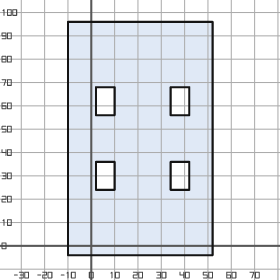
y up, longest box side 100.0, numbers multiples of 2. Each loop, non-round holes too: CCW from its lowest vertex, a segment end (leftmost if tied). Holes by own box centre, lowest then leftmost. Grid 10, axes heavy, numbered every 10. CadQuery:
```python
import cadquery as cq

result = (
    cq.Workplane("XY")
    .moveTo(-10.0, -4.0)
    .lineTo(52.0, -4.0)
    .lineTo(52.0, 96.0)
    .lineTo(-10.0, 96.0)
    .close()
    .moveTo(2.0, 24.0)
    .lineTo(10.0, 24.0)
    .lineTo(10.0, 36.0)
    .lineTo(2.0, 36.0)
    .close()
    .moveTo(34.0, 24.0)
    .lineTo(42.0, 24.0)
    .lineTo(42.0, 36.0)
    .lineTo(34.0, 36.0)
    .close()
    .moveTo(2.0, 56.0)
    .lineTo(10.0, 56.0)
    .lineTo(10.0, 68.0)
    .lineTo(2.0, 68.0)
    .close()
    .moveTo(34.0, 56.0)
    .lineTo(42.0, 56.0)
    .lineTo(42.0, 68.0)
    .lineTo(34.0, 68.0)
    .close()
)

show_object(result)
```